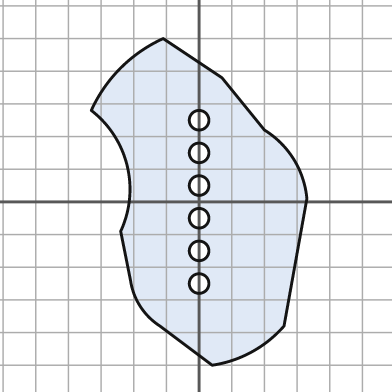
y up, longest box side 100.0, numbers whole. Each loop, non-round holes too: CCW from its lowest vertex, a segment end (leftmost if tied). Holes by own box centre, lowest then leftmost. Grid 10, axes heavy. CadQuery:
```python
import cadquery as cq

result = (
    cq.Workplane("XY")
    .moveTo(4.0, -50.0)
    .threePointArc((16.0, -46.0), (26.0, -38.0))
    .lineTo(33.0, 1.0)
    .threePointArc((29.0, 13.0), (20.0, 22.0))
    .lineTo(7.0, 38.0)
    .lineTo(-11.0, 50.0)
    .threePointArc((-24.0, 41.0), (-33.0, 28.0))
    .threePointArc((-22.0, 11.0), (-24.0, -9.0))
    .lineTo(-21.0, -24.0)
    .threePointArc((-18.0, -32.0), (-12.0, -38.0))
    .close()
    .moveTo(0.0, -25.0)
    .circle(3.0)
    .moveTo(0.0, -15.0)
    .circle(3.0)
    .moveTo(0.0, -5.0)
    .circle(3.0)
    .moveTo(0.0, 5.0)
    .circle(3.0)
    .moveTo(0.0, 15.0)
    .circle(3.0)
    .moveTo(0.0, 25.0)
    .circle(3.0)
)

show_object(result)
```